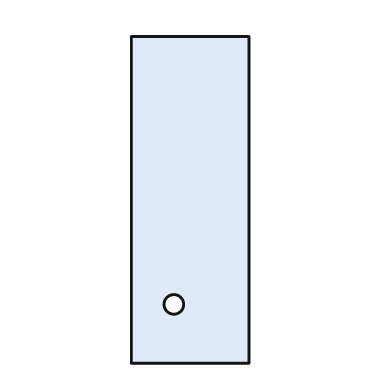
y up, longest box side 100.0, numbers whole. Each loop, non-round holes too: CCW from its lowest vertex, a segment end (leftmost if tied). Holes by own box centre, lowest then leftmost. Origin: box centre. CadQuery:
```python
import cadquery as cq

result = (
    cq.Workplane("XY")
    .moveTo(-18.0, -50.0)
    .lineTo(18.0, -50.0)
    .lineTo(18.0, 50.0)
    .lineTo(-18.0, 50.0)
    .close()
    .moveTo(-5.0, -32.0)
    .circle(3.0)
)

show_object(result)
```